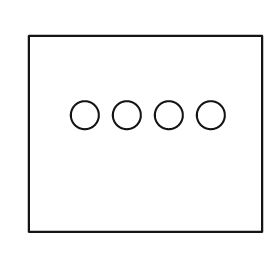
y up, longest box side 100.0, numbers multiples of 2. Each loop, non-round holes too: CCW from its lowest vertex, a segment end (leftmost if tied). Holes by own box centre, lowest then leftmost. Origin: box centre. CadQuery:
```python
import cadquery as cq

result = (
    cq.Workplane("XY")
    .moveTo(-50.0, -42.0)
    .lineTo(50.0, -42.0)
    .lineTo(50.0, 42.0)
    .lineTo(-50.0, 42.0)
    .close()
    .moveTo(-26.0, 8.0)
    .circle(6.0)
    .moveTo(-8.0, 8.0)
    .circle(6.0)
    .moveTo(10.0, 8.0)
    .circle(6.0)
    .moveTo(28.0, 8.0)
    .circle(6.0)
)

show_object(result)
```